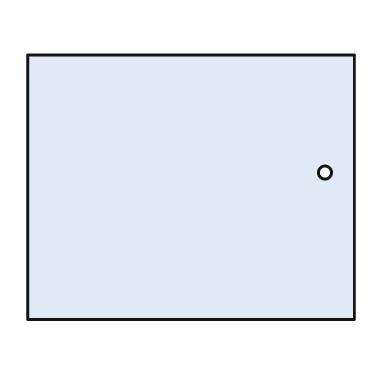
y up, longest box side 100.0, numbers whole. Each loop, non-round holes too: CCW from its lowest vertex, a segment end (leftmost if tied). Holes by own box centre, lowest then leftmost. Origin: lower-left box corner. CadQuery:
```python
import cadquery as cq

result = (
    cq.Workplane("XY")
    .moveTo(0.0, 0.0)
    .lineTo(100.0, 0.0)
    .lineTo(100.0, 81.0)
    .lineTo(0.0, 81.0)
    .close()
    .moveTo(91.0, 45.0)
    .circle(2.0)
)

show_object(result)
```